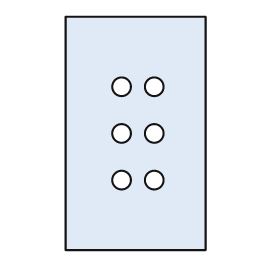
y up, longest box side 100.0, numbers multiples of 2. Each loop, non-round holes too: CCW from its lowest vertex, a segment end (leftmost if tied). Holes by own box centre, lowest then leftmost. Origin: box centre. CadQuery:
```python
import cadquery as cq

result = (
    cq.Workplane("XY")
    .moveTo(-30.0, -50.0)
    .lineTo(30.0, -50.0)
    .lineTo(30.0, 50.0)
    .lineTo(-30.0, 50.0)
    .close()
    .moveTo(-6.0, -20.0)
    .circle(4.0)
    .moveTo(8.0, -20.0)
    .circle(4.0)
    .moveTo(-6.0, 0.0)
    .circle(4.0)
    .moveTo(8.0, 0.0)
    .circle(4.0)
    .moveTo(-6.0, 20.0)
    .circle(4.0)
    .moveTo(8.0, 20.0)
    .circle(4.0)
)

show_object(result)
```